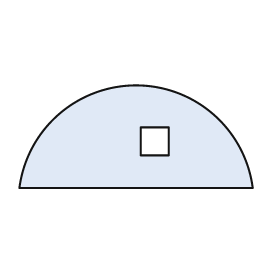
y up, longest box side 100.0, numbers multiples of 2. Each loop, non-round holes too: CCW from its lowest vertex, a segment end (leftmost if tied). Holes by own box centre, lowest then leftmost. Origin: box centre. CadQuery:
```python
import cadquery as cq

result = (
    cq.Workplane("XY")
    .moveTo(-50.0, -22.0)
    .lineTo(50.0, -22.0)
    .threePointArc((0.0, 22.0), (-50.0, -22.0))
    .close()
    .moveTo(2.0, -8.0)
    .lineTo(14.0, -8.0)
    .lineTo(14.0, 4.0)
    .lineTo(2.0, 4.0)
    .close()
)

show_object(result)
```